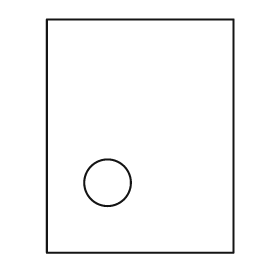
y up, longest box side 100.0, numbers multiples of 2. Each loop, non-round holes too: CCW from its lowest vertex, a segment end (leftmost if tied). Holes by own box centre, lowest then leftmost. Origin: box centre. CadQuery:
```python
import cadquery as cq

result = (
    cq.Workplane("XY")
    .moveTo(-40.0, -50.0)
    .lineTo(40.0, -50.0)
    .lineTo(40.0, 50.0)
    .lineTo(-40.0, 50.0)
    .close()
    .moveTo(-14.0, -20.0)
    .circle(10.0)
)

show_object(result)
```